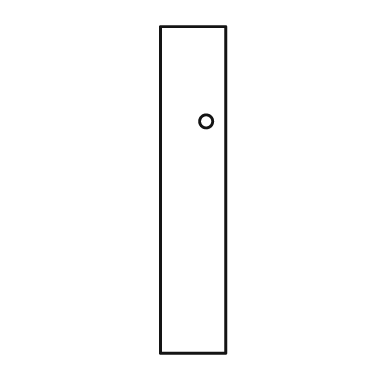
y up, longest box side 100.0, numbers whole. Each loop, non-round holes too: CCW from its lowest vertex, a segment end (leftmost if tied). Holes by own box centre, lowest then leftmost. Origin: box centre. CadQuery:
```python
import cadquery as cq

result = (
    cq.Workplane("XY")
    .moveTo(-10.0, -50.0)
    .lineTo(10.0, -50.0)
    .lineTo(10.0, 50.0)
    .lineTo(-10.0, 50.0)
    .close()
    .moveTo(4.0, 21.0)
    .circle(2.0)
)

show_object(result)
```